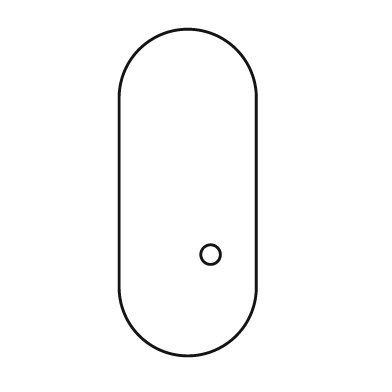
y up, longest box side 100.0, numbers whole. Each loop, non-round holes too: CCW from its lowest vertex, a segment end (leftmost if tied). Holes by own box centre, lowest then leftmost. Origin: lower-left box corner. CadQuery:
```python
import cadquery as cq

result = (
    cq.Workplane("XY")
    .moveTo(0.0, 21.0)
    .threePointArc((21.0, 0.0), (42.0, 21.0))
    .lineTo(42.0, 79.0)
    .threePointArc((21.0, 100.0), (0.0, 79.0))
    .close()
    .moveTo(28.0, 31.0)
    .circle(3.0)
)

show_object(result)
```